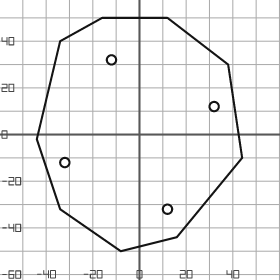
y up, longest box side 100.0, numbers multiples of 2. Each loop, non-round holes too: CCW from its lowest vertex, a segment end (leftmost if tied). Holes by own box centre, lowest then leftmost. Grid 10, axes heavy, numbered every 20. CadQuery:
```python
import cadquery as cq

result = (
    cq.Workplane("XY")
    .moveTo(-8.0, -50.0)
    .lineTo(16.0, -44.0)
    .lineTo(44.0, -10.0)
    .lineTo(38.0, 30.0)
    .lineTo(12.0, 50.0)
    .lineTo(-16.0, 50.0)
    .lineTo(-34.0, 40.0)
    .lineTo(-44.0, -2.0)
    .lineTo(-34.0, -32.0)
    .close()
    .moveTo(12.0, -32.0)
    .circle(2.0)
    .moveTo(-32.0, -12.0)
    .circle(2.0)
    .moveTo(32.0, 12.0)
    .circle(2.0)
    .moveTo(-12.0, 32.0)
    .circle(2.0)
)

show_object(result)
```